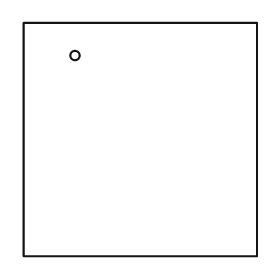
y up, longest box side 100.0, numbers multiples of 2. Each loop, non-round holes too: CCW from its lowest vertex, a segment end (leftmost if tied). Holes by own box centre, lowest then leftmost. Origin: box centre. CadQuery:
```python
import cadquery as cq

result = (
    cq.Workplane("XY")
    .moveTo(-50.0, -50.0)
    .lineTo(50.0, -50.0)
    .lineTo(50.0, 50.0)
    .lineTo(-50.0, 50.0)
    .close()
    .moveTo(-28.0, 36.0)
    .circle(2.0)
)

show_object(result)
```